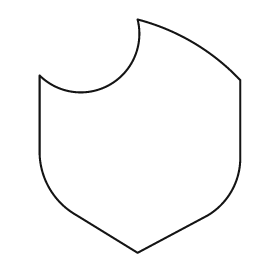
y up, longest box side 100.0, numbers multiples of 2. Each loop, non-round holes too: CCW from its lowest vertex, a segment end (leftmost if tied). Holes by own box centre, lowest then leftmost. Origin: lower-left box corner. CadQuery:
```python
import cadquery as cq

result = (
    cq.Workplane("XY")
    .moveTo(42.0, 0.0)
    .lineTo(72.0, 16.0)
    .threePointArc((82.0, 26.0), (86.0, 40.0))
    .lineTo(86.0, 74.0)
    .threePointArc((66.0, 90.0), (42.0, 100.0))
    .threePointArc((30.0, 72.0), (0.0, 76.0))
    .lineTo(0.0, 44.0)
    .threePointArc((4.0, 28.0), (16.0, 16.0))
    .close()
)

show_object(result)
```